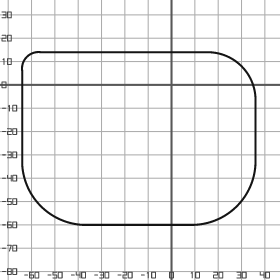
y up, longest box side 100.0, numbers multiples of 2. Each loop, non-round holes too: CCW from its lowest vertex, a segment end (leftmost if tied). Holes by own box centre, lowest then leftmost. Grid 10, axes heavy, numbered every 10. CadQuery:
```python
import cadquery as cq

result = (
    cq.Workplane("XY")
    .moveTo(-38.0, -60.0)
    .lineTo(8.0, -60.0)
    .threePointArc((28.0, -52.0), (36.0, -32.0))
    .lineTo(36.0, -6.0)
    .threePointArc((30.0, 8.0), (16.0, 14.0))
    .lineTo(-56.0, 14.0)
    .threePointArc((-62.0, 12.0), (-64.0, 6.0))
    .lineTo(-64.0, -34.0)
    .threePointArc((-56.0, -52.0), (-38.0, -60.0))
    .close()
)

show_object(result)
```